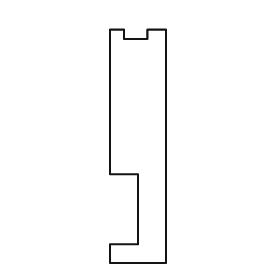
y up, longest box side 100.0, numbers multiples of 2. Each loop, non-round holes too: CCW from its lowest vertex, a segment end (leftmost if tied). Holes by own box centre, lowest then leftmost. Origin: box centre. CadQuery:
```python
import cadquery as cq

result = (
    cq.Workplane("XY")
    .moveTo(-12.0, -50.0)
    .lineTo(12.0, -50.0)
    .lineTo(12.0, 50.0)
    .lineTo(4.0, 50.0)
    .lineTo(4.0, 46.0)
    .lineTo(-6.0, 46.0)
    .lineTo(-6.0, 50.0)
    .lineTo(-12.0, 50.0)
    .lineTo(-12.0, -12.0)
    .lineTo(0.0, -12.0)
    .lineTo(0.0, -42.0)
    .lineTo(-12.0, -42.0)
    .close()
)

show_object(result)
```